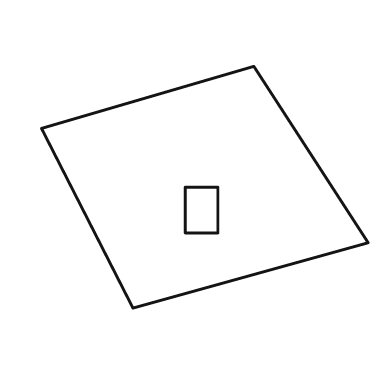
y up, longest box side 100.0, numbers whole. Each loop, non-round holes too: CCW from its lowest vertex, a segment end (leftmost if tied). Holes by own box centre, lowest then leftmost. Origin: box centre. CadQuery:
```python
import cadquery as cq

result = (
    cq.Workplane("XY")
    .moveTo(-22.0, -37.0)
    .lineTo(50.0, -17.0)
    .lineTo(15.0, 37.0)
    .lineTo(-50.0, 18.0)
    .close()
    .moveTo(-6.0, -14.0)
    .lineTo(4.0, -14.0)
    .lineTo(4.0, 0.0)
    .lineTo(-6.0, 0.0)
    .close()
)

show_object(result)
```